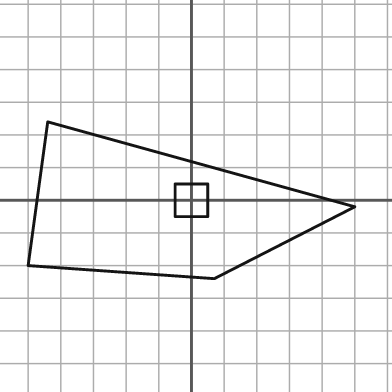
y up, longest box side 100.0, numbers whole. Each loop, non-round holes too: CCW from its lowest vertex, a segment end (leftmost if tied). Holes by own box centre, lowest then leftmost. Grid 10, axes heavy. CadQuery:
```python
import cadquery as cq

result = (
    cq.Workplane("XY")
    .moveTo(7.0, -24.0)
    .lineTo(50.0, -2.0)
    .lineTo(-44.0, 24.0)
    .lineTo(-50.0, -20.0)
    .close()
    .moveTo(-5.0, -5.0)
    .lineTo(5.0, -5.0)
    .lineTo(5.0, 5.0)
    .lineTo(-5.0, 5.0)
    .close()
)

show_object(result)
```